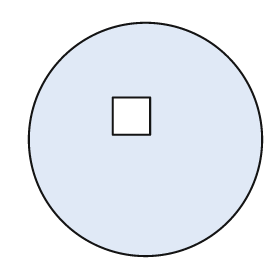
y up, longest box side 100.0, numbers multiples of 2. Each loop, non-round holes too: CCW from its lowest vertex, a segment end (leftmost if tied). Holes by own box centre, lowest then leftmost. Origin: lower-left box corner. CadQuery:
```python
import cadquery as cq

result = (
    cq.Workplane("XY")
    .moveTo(50.0, 50.0)
    .circle(50.0)
    .moveTo(36.0, 52.0)
    .lineTo(52.0, 52.0)
    .lineTo(52.0, 68.0)
    .lineTo(36.0, 68.0)
    .close()
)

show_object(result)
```